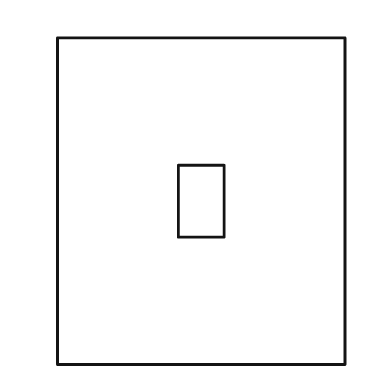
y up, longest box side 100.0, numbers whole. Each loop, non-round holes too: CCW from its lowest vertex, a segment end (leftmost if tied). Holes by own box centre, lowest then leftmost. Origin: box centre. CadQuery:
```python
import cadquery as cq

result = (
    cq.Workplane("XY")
    .moveTo(-44.0, -50.0)
    .lineTo(44.0, -50.0)
    .lineTo(44.0, 50.0)
    .lineTo(-44.0, 50.0)
    .close()
    .moveTo(-7.0, -11.0)
    .lineTo(7.0, -11.0)
    .lineTo(7.0, 11.0)
    .lineTo(-7.0, 11.0)
    .close()
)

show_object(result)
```